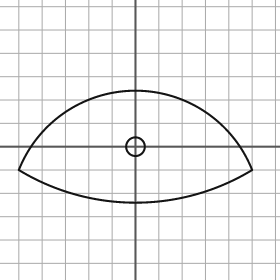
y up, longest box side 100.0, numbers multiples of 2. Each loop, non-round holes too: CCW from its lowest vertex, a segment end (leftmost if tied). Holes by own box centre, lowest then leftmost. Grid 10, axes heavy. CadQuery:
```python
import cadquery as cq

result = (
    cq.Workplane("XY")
    .moveTo(-50.0, -10.0)
    .threePointArc((0.0, -24.0), (50.0, -10.0))
    .threePointArc((0.0, 24.0), (-50.0, -10.0))
    .close()
    .moveTo(0.0, 0.0)
    .circle(4.0)
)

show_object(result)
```